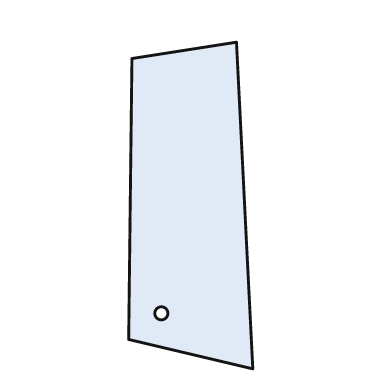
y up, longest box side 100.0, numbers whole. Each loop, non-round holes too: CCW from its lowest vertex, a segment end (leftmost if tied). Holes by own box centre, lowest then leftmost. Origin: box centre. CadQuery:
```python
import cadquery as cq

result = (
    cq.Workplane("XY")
    .moveTo(19.0, -50.0)
    .lineTo(14.0, 50.0)
    .lineTo(-18.0, 45.0)
    .lineTo(-19.0, -41.0)
    .close()
    .moveTo(-9.0, -33.0)
    .circle(2.0)
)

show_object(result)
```